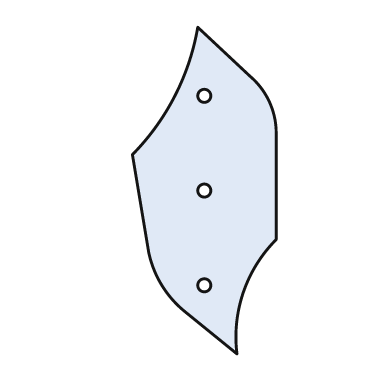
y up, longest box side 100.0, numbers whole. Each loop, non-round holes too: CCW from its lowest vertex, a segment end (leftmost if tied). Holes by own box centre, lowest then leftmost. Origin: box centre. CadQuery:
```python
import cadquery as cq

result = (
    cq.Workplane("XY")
    .moveTo(10.0, -50.0)
    .threePointArc((12.0, -31.0), (22.0, -15.0))
    .lineTo(22.0, 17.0)
    .threePointArc((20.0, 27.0), (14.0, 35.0))
    .lineTo(-2.0, 50.0)
    .threePointArc((-9.0, 29.0), (-22.0, 11.0))
    .lineTo(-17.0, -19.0)
    .threePointArc((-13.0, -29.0), (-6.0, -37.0))
    .close()
    .moveTo(0.0, -29.0)
    .circle(2.0)
    .moveTo(0.0, 0.0)
    .circle(2.0)
    .moveTo(0.0, 29.0)
    .circle(2.0)
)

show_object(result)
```